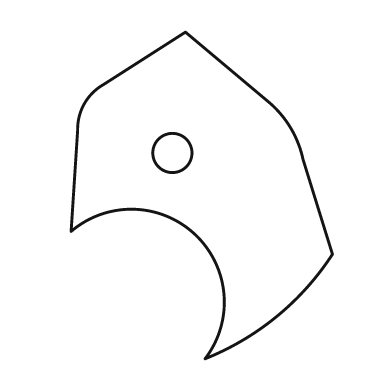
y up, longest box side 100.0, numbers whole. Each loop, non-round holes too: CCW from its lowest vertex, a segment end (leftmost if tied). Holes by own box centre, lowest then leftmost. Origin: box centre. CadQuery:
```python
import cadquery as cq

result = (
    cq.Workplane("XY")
    .moveTo(1.0, -50.0)
    .threePointArc((23.0, -37.0), (40.0, -18.0))
    .lineTo(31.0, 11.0)
    .threePointArc((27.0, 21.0), (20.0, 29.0))
    .lineTo(-5.0, 50.0)
    .lineTo(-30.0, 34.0)
    .threePointArc((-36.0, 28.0), (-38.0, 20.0))
    .lineTo(-40.0, -11.0)
    .threePointArc((-2.0, -12.0), (1.0, -50.0))
    .close()
    .moveTo(-9.0, 13.0)
    .circle(6.0)
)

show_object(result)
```